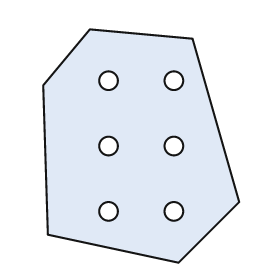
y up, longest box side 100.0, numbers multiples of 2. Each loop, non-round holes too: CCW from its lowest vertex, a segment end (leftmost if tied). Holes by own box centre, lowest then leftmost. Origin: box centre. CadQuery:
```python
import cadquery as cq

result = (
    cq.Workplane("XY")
    .moveTo(16.0, -50.0)
    .lineTo(42.0, -24.0)
    .lineTo(22.0, 46.0)
    .lineTo(-22.0, 50.0)
    .lineTo(-42.0, 26.0)
    .lineTo(-40.0, -38.0)
    .close()
    .moveTo(-14.0, -28.0)
    .circle(4.0)
    .moveTo(14.0, -28.0)
    .circle(4.0)
    .moveTo(-14.0, 0.0)
    .circle(4.0)
    .moveTo(14.0, 0.0)
    .circle(4.0)
    .moveTo(-14.0, 28.0)
    .circle(4.0)
    .moveTo(14.0, 28.0)
    .circle(4.0)
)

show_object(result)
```